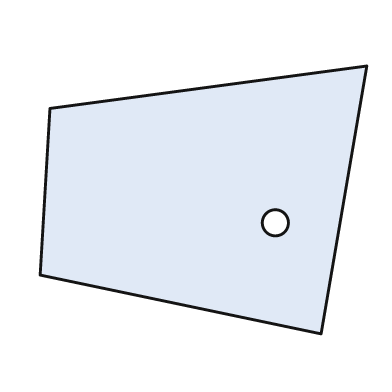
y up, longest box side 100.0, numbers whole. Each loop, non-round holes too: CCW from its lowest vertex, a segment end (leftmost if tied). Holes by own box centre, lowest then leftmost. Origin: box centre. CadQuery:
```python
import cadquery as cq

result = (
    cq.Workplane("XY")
    .moveTo(36.0, -41.0)
    .lineTo(50.0, 41.0)
    .lineTo(-47.0, 28.0)
    .lineTo(-50.0, -23.0)
    .close()
    .moveTo(22.0, -7.0)
    .circle(4.0)
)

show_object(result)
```